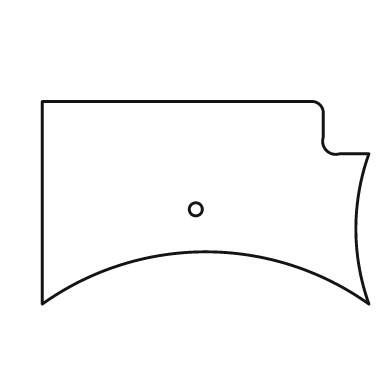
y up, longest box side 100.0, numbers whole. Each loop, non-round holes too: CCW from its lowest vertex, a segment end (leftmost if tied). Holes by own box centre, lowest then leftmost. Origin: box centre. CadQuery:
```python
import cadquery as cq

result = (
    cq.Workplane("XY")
    .moveTo(-50.0, -31.0)
    .threePointArc((0.0, -15.0), (50.0, -31.0))
    .threePointArc((46.0, -8.0), (50.0, 15.0))
    .lineTo(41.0, 15.0)
    .threePointArc((37.0, 16.0), (36.0, 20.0))
    .lineTo(36.0, 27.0)
    .threePointArc((35.0, 30.0), (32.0, 31.0))
    .lineTo(-50.0, 31.0)
    .close()
    .moveTo(-3.0, -2.0)
    .circle(2.0)
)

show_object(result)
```